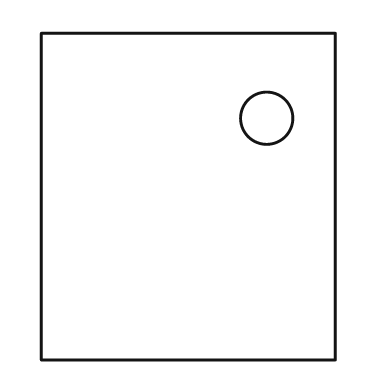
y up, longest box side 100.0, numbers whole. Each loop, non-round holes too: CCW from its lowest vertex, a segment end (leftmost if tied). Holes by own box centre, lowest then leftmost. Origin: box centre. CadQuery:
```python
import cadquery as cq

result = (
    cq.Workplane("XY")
    .moveTo(-45.0, -50.0)
    .lineTo(45.0, -50.0)
    .lineTo(45.0, 50.0)
    .lineTo(-45.0, 50.0)
    .close()
    .moveTo(24.0, 24.0)
    .circle(8.0)
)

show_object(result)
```